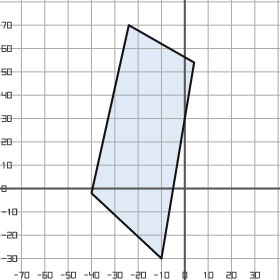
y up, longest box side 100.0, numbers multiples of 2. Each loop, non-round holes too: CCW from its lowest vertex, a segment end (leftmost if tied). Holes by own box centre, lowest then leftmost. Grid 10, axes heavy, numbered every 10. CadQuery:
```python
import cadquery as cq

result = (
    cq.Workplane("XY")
    .moveTo(-10.0, -30.0)
    .lineTo(4.0, 54.0)
    .lineTo(-24.0, 70.0)
    .lineTo(-40.0, -2.0)
    .close()
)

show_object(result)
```